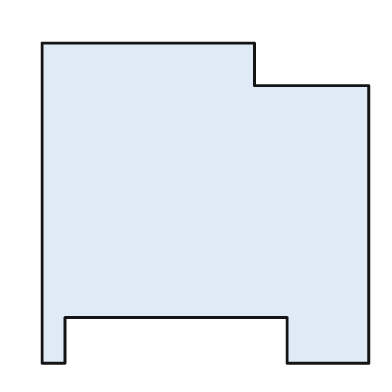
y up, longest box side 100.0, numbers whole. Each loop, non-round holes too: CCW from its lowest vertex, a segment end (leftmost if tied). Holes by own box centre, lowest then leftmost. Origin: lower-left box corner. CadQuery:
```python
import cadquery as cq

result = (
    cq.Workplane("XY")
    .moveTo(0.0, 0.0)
    .lineTo(7.0, 0.0)
    .lineTo(7.0, 14.0)
    .lineTo(75.0, 14.0)
    .lineTo(75.0, 0.0)
    .lineTo(100.0, 0.0)
    .lineTo(100.0, 85.0)
    .lineTo(65.0, 85.0)
    .lineTo(65.0, 98.0)
    .lineTo(0.0, 98.0)
    .close()
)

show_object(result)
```